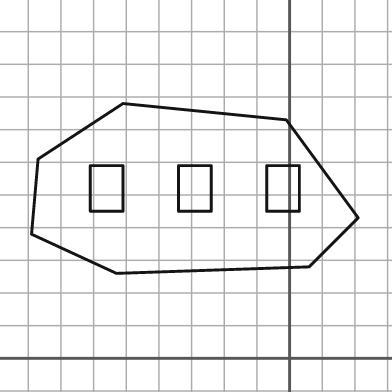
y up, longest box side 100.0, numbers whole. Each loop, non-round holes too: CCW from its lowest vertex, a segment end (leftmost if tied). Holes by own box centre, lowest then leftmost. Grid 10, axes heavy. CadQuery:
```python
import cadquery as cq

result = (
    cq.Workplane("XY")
    .moveTo(-53.0, 26.0)
    .lineTo(6.0, 28.0)
    .lineTo(21.0, 43.0)
    .lineTo(-1.0, 73.0)
    .lineTo(-51.0, 78.0)
    .lineTo(-77.0, 61.0)
    .lineTo(-79.0, 38.0)
    .close()
    .moveTo(-61.0, 45.0)
    .lineTo(-51.0, 45.0)
    .lineTo(-51.0, 59.0)
    .lineTo(-61.0, 59.0)
    .close()
    .moveTo(-34.0, 45.0)
    .lineTo(-24.0, 45.0)
    .lineTo(-24.0, 59.0)
    .lineTo(-34.0, 59.0)
    .close()
    .moveTo(-7.0, 45.0)
    .lineTo(3.0, 45.0)
    .lineTo(3.0, 59.0)
    .lineTo(-7.0, 59.0)
    .close()
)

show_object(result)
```